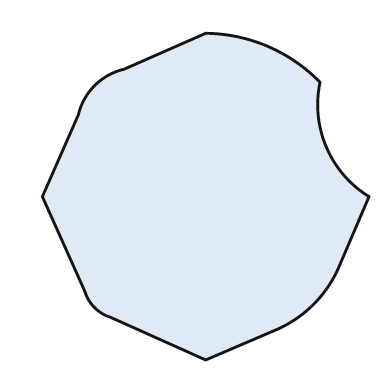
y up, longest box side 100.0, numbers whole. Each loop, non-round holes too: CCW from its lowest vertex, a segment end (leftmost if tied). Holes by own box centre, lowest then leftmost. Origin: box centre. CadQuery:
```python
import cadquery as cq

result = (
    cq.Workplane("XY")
    .moveTo(0.0, -50.0)
    .lineTo(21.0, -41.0)
    .threePointArc((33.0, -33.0), (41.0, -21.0))
    .lineTo(50.0, 0.0)
    .threePointArc((37.0, 15.0), (35.0, 35.0))
    .threePointArc((19.0, 46.0), (0.0, 50.0))
    .lineTo(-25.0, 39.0)
    .threePointArc((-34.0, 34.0), (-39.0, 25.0))
    .lineTo(-50.0, 0.0)
    .lineTo(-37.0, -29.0)
    .threePointArc((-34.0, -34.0), (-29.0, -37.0))
    .close()
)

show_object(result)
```